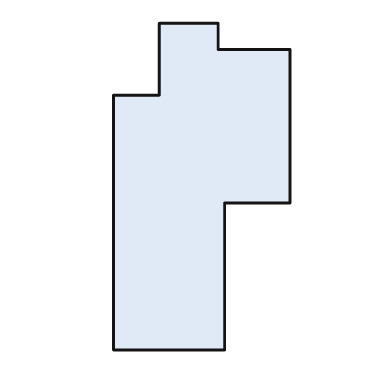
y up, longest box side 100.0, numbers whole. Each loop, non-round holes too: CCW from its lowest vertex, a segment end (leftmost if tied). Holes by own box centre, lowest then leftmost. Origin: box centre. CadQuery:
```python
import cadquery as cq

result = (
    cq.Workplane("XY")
    .moveTo(-27.0, -50.0)
    .lineTo(7.0, -50.0)
    .lineTo(7.0, -5.0)
    .lineTo(27.0, -5.0)
    .lineTo(27.0, 42.0)
    .lineTo(5.0, 42.0)
    .lineTo(5.0, 50.0)
    .lineTo(-13.0, 50.0)
    .lineTo(-13.0, 28.0)
    .lineTo(-27.0, 28.0)
    .close()
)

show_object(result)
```